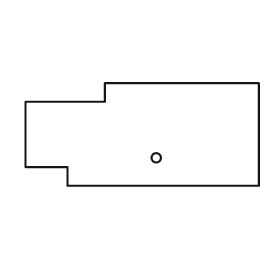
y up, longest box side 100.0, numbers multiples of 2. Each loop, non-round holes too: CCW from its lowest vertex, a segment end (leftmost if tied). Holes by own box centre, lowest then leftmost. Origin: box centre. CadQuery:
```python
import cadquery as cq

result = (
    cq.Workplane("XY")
    .moveTo(-32.0, -22.0)
    .lineTo(50.0, -22.0)
    .lineTo(50.0, 22.0)
    .lineTo(-16.0, 22.0)
    .lineTo(-16.0, 14.0)
    .lineTo(-50.0, 14.0)
    .lineTo(-50.0, -14.0)
    .lineTo(-32.0, -14.0)
    .close()
    .moveTo(6.0, -10.0)
    .circle(2.0)
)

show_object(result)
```